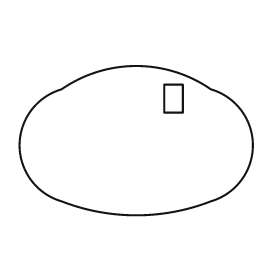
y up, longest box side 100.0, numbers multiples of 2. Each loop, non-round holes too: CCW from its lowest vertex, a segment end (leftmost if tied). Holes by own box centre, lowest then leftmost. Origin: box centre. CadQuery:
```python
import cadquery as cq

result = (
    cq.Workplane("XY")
    .moveTo(-32.0, -26.0)
    .threePointArc((0.0, -32.0), (32.0, -26.0))
    .threePointArc((50.0, -2.0), (32.0, 22.0))
    .threePointArc((0.0, 32.0), (-32.0, 22.0))
    .threePointArc((-50.0, -2.0), (-32.0, -26.0))
    .close()
    .moveTo(12.0, 12.0)
    .lineTo(20.0, 12.0)
    .lineTo(20.0, 24.0)
    .lineTo(12.0, 24.0)
    .close()
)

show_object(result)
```